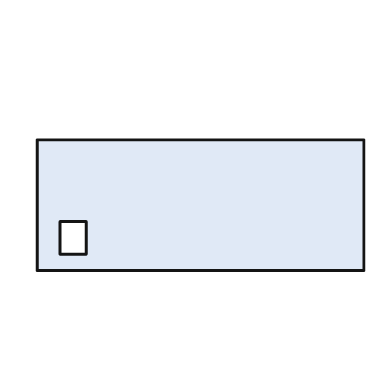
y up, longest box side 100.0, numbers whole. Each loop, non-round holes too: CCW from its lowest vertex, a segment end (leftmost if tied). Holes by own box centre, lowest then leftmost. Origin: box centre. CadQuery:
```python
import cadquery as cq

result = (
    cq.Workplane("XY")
    .moveTo(-50.0, -20.0)
    .lineTo(50.0, -20.0)
    .lineTo(50.0, 20.0)
    .lineTo(-50.0, 20.0)
    .close()
    .moveTo(-43.0, -15.0)
    .lineTo(-35.0, -15.0)
    .lineTo(-35.0, -5.0)
    .lineTo(-43.0, -5.0)
    .close()
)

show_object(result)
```